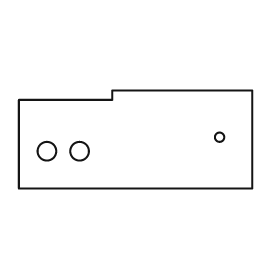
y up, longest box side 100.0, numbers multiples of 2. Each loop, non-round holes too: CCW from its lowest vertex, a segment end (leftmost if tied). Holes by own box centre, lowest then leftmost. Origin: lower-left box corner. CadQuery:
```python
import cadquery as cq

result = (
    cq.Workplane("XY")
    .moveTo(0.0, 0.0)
    .lineTo(100.0, 0.0)
    .lineTo(100.0, 42.0)
    .lineTo(40.0, 42.0)
    .lineTo(40.0, 38.0)
    .lineTo(0.0, 38.0)
    .close()
    .moveTo(12.0, 16.0)
    .circle(4.0)
    .moveTo(26.0, 16.0)
    .circle(4.0)
    .moveTo(86.0, 22.0)
    .circle(2.0)
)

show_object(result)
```